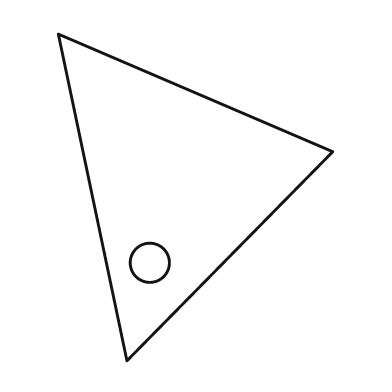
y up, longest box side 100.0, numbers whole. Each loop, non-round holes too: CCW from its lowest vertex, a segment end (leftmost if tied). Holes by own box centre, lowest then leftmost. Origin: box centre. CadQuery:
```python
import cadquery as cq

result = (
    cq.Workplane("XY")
    .moveTo(-21.0, -50.0)
    .lineTo(42.0, 14.0)
    .lineTo(-42.0, 50.0)
    .close()
    .moveTo(-14.0, -20.0)
    .circle(6.0)
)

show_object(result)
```